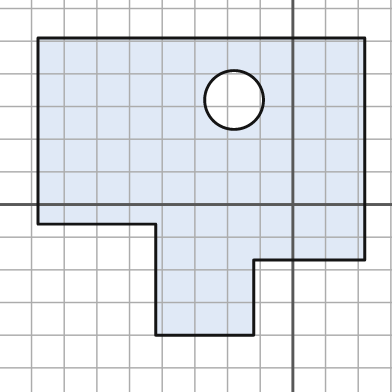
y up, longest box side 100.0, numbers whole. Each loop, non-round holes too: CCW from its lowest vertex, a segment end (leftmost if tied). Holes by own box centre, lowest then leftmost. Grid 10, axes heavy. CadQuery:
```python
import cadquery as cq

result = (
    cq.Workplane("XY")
    .moveTo(-42.0, -40.0)
    .lineTo(-12.0, -40.0)
    .lineTo(-12.0, -17.0)
    .lineTo(22.0, -17.0)
    .lineTo(22.0, 51.0)
    .lineTo(-78.0, 51.0)
    .lineTo(-78.0, -6.0)
    .lineTo(-42.0, -6.0)
    .close()
    .moveTo(-18.0, 32.0)
    .circle(9.0)
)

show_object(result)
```